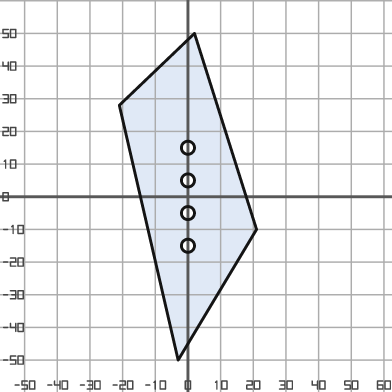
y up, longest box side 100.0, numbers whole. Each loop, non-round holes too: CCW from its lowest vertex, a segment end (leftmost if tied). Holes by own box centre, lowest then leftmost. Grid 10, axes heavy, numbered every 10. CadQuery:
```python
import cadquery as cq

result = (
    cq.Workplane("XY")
    .moveTo(-3.0, -50.0)
    .lineTo(21.0, -10.0)
    .lineTo(2.0, 50.0)
    .lineTo(-21.0, 28.0)
    .close()
    .moveTo(0.0, -15.0)
    .circle(2.0)
    .moveTo(0.0, -5.0)
    .circle(2.0)
    .moveTo(0.0, 5.0)
    .circle(2.0)
    .moveTo(0.0, 15.0)
    .circle(2.0)
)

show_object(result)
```